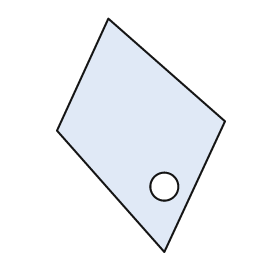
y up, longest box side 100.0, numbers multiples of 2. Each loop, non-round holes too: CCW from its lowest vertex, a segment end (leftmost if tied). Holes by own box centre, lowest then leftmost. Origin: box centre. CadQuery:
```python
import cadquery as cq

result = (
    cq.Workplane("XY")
    .moveTo(10.0, -50.0)
    .lineTo(36.0, 6.0)
    .lineTo(-14.0, 50.0)
    .lineTo(-36.0, 2.0)
    .close()
    .moveTo(10.0, -22.0)
    .circle(6.0)
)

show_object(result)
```